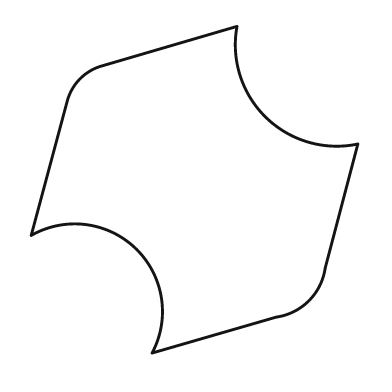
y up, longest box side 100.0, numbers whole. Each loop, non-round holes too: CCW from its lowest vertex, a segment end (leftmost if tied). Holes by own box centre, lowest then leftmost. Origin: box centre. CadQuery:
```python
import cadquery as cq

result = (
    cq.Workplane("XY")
    .moveTo(-13.0, -50.0)
    .lineTo(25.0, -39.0)
    .threePointArc((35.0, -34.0), (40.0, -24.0))
    .lineTo(50.0, 14.0)
    .threePointArc((22.0, 22.0), (13.0, 50.0))
    .lineTo(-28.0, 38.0)
    .threePointArc((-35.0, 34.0), (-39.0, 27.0))
    .lineTo(-50.0, -14.0)
    .threePointArc((-18.0, -18.0), (-13.0, -50.0))
    .close()
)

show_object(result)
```